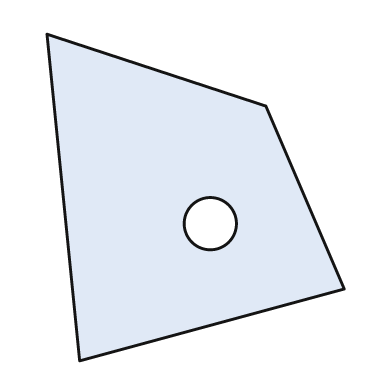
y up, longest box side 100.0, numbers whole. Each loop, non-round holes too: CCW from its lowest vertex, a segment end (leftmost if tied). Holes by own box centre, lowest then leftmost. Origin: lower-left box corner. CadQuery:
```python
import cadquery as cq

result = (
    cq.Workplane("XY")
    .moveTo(10.0, 0.0)
    .lineTo(91.0, 22.0)
    .lineTo(67.0, 78.0)
    .lineTo(0.0, 100.0)
    .close()
    .moveTo(50.0, 42.0)
    .circle(8.0)
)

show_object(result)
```